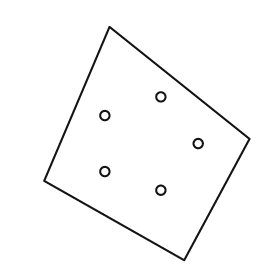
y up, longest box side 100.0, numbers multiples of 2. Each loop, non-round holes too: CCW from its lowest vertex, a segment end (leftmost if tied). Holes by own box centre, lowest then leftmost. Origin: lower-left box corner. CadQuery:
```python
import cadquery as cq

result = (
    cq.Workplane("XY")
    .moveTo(60.0, 0.0)
    .lineTo(88.0, 52.0)
    .lineTo(28.0, 100.0)
    .lineTo(0.0, 34.0)
    .close()
    .moveTo(50.0, 30.0)
    .circle(2.0)
    .moveTo(26.0, 38.0)
    .circle(2.0)
    .moveTo(66.0, 50.0)
    .circle(2.0)
    .moveTo(26.0, 62.0)
    .circle(2.0)
    .moveTo(50.0, 70.0)
    .circle(2.0)
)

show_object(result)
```